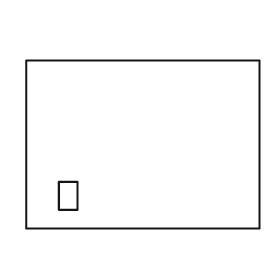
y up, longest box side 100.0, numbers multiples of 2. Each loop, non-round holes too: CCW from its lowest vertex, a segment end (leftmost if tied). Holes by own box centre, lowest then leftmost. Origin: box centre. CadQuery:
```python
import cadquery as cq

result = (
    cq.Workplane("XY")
    .moveTo(-50.0, -36.0)
    .lineTo(50.0, -36.0)
    .lineTo(50.0, 36.0)
    .lineTo(-50.0, 36.0)
    .close()
    .moveTo(-36.0, -28.0)
    .lineTo(-28.0, -28.0)
    .lineTo(-28.0, -16.0)
    .lineTo(-36.0, -16.0)
    .close()
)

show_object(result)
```